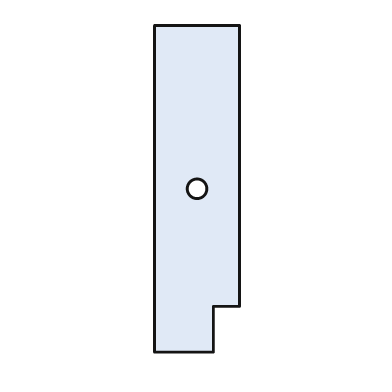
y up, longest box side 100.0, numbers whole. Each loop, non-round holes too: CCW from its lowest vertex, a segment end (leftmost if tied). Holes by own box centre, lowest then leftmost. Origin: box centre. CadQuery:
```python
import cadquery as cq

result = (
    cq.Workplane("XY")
    .moveTo(-13.0, -50.0)
    .lineTo(5.0, -50.0)
    .lineTo(5.0, -36.0)
    .lineTo(13.0, -36.0)
    .lineTo(13.0, 50.0)
    .lineTo(-13.0, 50.0)
    .close()
    .moveTo(0.0, 0.0)
    .circle(3.0)
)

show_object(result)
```